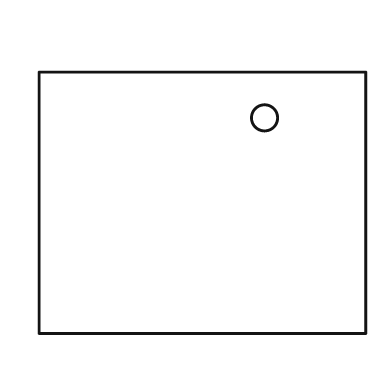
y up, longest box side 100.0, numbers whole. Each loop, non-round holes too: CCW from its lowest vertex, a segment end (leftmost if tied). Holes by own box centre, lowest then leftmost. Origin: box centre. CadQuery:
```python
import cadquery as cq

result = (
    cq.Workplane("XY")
    .moveTo(-50.0, -40.0)
    .lineTo(50.0, -40.0)
    .lineTo(50.0, 40.0)
    .lineTo(-50.0, 40.0)
    .close()
    .moveTo(19.0, 26.0)
    .circle(4.0)
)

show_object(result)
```